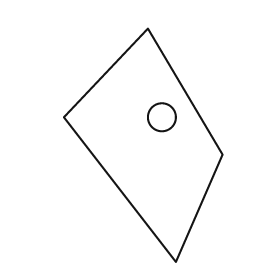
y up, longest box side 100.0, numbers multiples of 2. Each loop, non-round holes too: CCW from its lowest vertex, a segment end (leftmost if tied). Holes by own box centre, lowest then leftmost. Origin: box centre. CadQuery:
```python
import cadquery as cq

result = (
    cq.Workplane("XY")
    .moveTo(14.0, -50.0)
    .lineTo(34.0, -4.0)
    .lineTo(2.0, 50.0)
    .lineTo(-34.0, 12.0)
    .close()
    .moveTo(8.0, 12.0)
    .circle(6.0)
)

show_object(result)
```